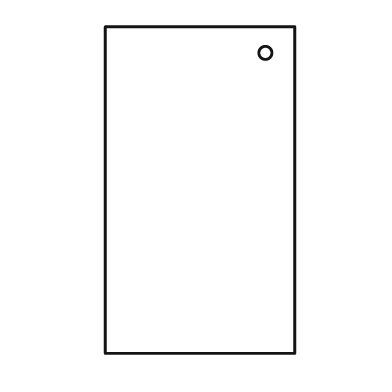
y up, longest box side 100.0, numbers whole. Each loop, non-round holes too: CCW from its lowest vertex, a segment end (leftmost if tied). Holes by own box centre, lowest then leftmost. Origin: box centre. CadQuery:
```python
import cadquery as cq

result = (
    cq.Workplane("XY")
    .moveTo(-29.0, -50.0)
    .lineTo(29.0, -50.0)
    .lineTo(29.0, 50.0)
    .lineTo(-29.0, 50.0)
    .close()
    .moveTo(20.0, 42.0)
    .circle(2.0)
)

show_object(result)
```